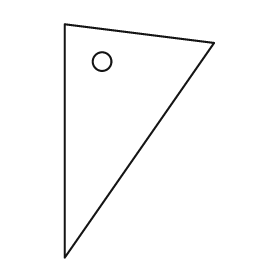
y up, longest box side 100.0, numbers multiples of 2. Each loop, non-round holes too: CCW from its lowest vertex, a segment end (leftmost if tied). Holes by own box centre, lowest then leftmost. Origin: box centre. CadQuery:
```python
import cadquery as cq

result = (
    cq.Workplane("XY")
    .moveTo(-32.0, -50.0)
    .lineTo(32.0, 42.0)
    .lineTo(-32.0, 50.0)
    .close()
    .moveTo(-16.0, 34.0)
    .circle(4.0)
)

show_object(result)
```